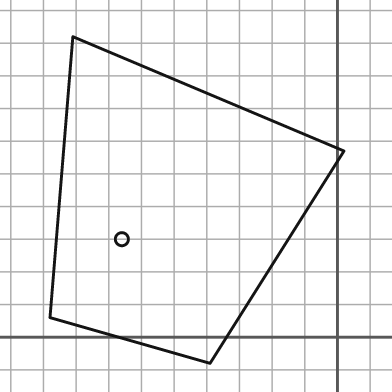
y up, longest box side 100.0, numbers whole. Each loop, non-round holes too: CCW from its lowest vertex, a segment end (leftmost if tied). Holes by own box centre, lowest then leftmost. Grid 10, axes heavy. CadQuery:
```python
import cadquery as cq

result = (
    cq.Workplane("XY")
    .moveTo(-39.0, -8.0)
    .lineTo(2.0, 57.0)
    .lineTo(-81.0, 92.0)
    .lineTo(-88.0, 6.0)
    .close()
    .moveTo(-66.0, 30.0)
    .circle(2.0)
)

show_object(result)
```